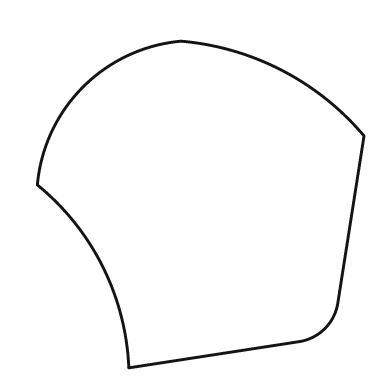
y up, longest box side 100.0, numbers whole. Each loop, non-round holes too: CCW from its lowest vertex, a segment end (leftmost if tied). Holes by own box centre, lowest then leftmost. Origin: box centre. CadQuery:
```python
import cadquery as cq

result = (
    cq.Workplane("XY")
    .moveTo(-22.0, -50.0)
    .lineTo(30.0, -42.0)
    .threePointArc((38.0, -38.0), (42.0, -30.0))
    .lineTo(50.0, 21.0)
    .threePointArc((25.0, 41.0), (-6.0, 50.0))
    .threePointArc((-36.0, 36.0), (-50.0, 6.0))
    .threePointArc((-30.0, -19.0), (-22.0, -50.0))
    .close()
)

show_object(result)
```